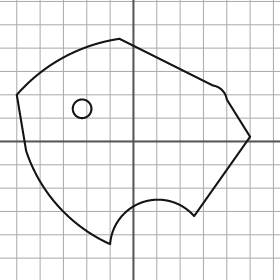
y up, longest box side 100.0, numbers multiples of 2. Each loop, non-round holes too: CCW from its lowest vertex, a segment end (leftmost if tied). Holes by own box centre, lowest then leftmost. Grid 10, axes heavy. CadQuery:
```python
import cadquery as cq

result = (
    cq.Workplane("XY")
    .moveTo(-10.0, -44.0)
    .threePointArc((4.0, -26.0), (26.0, -32.0))
    .lineTo(50.0, 2.0)
    .lineTo(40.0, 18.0)
    .threePointArc((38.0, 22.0), (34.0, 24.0))
    .lineTo(-6.0, 44.0)
    .threePointArc((-30.0, 36.0), (-50.0, 20.0))
    .lineTo(-46.0, -4.0)
    .threePointArc((-32.0, -28.0), (-10.0, -44.0))
    .close()
    .moveTo(-22.0, 14.0)
    .circle(4.0)
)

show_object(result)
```